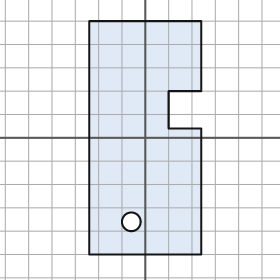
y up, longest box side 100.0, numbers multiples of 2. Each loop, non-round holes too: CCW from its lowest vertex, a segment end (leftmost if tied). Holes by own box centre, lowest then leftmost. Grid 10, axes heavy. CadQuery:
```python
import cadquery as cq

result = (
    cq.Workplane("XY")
    .moveTo(-24.0, -50.0)
    .lineTo(24.0, -50.0)
    .lineTo(24.0, 4.0)
    .lineTo(10.0, 4.0)
    .lineTo(10.0, 20.0)
    .lineTo(24.0, 20.0)
    .lineTo(24.0, 50.0)
    .lineTo(-24.0, 50.0)
    .close()
    .moveTo(-6.0, -36.0)
    .circle(4.0)
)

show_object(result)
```